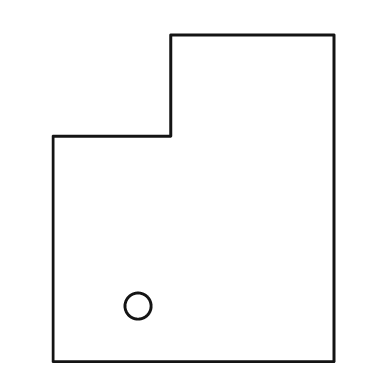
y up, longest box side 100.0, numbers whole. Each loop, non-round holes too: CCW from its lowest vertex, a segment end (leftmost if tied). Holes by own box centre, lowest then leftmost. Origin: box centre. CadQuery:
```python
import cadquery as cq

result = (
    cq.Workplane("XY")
    .moveTo(-43.0, -50.0)
    .lineTo(43.0, -50.0)
    .lineTo(43.0, 50.0)
    .lineTo(-7.0, 50.0)
    .lineTo(-7.0, 19.0)
    .lineTo(-43.0, 19.0)
    .close()
    .moveTo(-17.0, -33.0)
    .circle(4.0)
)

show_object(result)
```